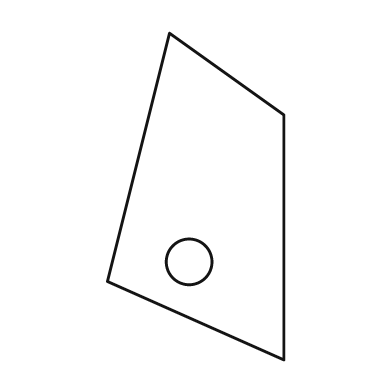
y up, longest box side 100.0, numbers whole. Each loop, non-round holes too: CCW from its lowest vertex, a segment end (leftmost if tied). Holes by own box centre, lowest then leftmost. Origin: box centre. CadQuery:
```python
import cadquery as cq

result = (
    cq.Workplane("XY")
    .moveTo(27.0, -50.0)
    .lineTo(27.0, 25.0)
    .lineTo(-8.0, 50.0)
    .lineTo(-27.0, -26.0)
    .close()
    .moveTo(-2.0, -20.0)
    .circle(7.0)
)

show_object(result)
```